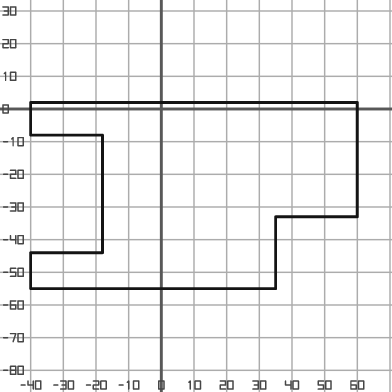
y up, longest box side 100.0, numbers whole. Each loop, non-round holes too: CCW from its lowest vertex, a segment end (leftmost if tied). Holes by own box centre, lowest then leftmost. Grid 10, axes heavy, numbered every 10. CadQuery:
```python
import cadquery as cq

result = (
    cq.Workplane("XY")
    .moveTo(-40.0, -55.0)
    .lineTo(35.0, -55.0)
    .lineTo(35.0, -33.0)
    .lineTo(60.0, -33.0)
    .lineTo(60.0, 2.0)
    .lineTo(-40.0, 2.0)
    .lineTo(-40.0, -8.0)
    .lineTo(-18.0, -8.0)
    .lineTo(-18.0, -44.0)
    .lineTo(-40.0, -44.0)
    .close()
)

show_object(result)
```